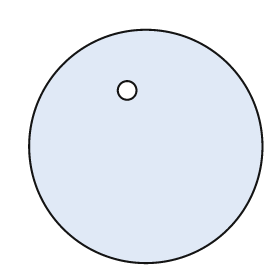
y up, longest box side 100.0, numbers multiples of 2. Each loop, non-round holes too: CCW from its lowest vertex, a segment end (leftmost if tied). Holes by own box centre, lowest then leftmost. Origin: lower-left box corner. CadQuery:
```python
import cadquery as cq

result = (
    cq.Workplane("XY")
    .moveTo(50.0, 50.0)
    .circle(50.0)
    .moveTo(42.0, 74.0)
    .circle(4.0)
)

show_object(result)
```